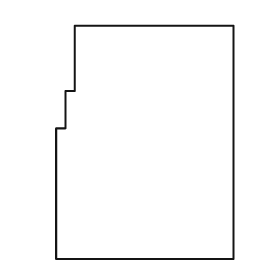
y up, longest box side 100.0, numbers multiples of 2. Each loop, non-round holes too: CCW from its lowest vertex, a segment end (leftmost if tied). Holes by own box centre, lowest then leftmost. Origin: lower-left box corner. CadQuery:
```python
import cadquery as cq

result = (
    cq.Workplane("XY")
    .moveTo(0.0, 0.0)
    .lineTo(76.0, 0.0)
    .lineTo(76.0, 100.0)
    .lineTo(8.0, 100.0)
    .lineTo(8.0, 72.0)
    .lineTo(4.0, 72.0)
    .lineTo(4.0, 56.0)
    .lineTo(0.0, 56.0)
    .close()
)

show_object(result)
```